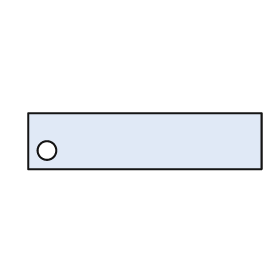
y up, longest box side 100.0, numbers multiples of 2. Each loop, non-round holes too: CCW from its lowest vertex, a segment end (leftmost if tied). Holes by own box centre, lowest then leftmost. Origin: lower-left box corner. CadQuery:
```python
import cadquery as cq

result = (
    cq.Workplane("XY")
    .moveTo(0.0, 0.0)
    .lineTo(100.0, 0.0)
    .lineTo(100.0, 24.0)
    .lineTo(0.0, 24.0)
    .close()
    .moveTo(8.0, 8.0)
    .circle(4.0)
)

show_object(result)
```